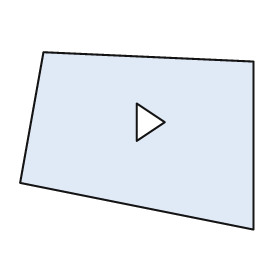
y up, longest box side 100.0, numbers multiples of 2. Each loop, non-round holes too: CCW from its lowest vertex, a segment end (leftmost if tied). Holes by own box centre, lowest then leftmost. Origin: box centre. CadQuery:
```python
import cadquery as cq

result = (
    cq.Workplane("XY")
    .moveTo(50.0, -38.0)
    .lineTo(50.0, 34.0)
    .lineTo(-40.0, 38.0)
    .lineTo(-50.0, -18.0)
    .close()
    .moveTo(0.0, 0.0)
    .lineTo(12.0, 8.0)
    .lineTo(0.0, 16.0)
    .close()
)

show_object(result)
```